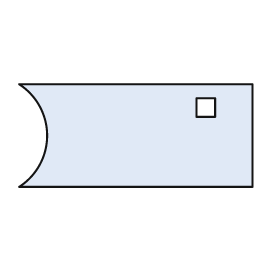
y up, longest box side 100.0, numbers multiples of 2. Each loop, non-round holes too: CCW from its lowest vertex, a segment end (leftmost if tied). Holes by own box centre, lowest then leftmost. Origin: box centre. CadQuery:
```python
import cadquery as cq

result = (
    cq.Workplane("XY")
    .moveTo(-50.0, -22.0)
    .lineTo(50.0, -22.0)
    .lineTo(50.0, 22.0)
    .lineTo(-50.0, 22.0)
    .threePointArc((-38.0, 0.0), (-50.0, -22.0))
    .close()
    .moveTo(26.0, 8.0)
    .lineTo(34.0, 8.0)
    .lineTo(34.0, 16.0)
    .lineTo(26.0, 16.0)
    .close()
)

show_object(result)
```